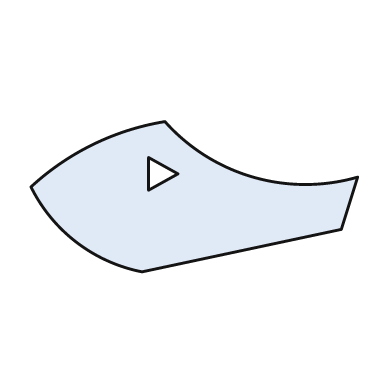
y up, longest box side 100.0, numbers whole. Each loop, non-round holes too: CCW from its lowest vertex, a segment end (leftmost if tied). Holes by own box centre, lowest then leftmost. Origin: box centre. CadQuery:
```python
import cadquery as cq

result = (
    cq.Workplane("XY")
    .moveTo(-16.0, -23.0)
    .lineTo(45.0, -10.0)
    .lineTo(50.0, 6.0)
    .threePointArc((18.0, 6.0), (-9.0, 23.0))
    .threePointArc((-31.0, 16.0), (-50.0, 3.0))
    .threePointArc((-36.0, -14.0), (-16.0, -23.0))
    .close()
    .moveTo(-14.0, 2.0)
    .lineTo(-5.0, 7.0)
    .lineTo(-14.0, 12.0)
    .close()
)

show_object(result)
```